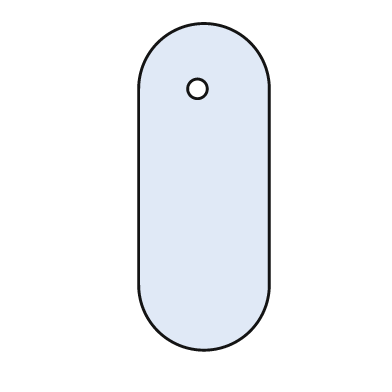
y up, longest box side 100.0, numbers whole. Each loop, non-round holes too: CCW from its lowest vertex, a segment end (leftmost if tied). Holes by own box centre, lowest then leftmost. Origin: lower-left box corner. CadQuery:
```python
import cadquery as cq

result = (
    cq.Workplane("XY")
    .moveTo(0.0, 20.0)
    .threePointArc((20.0, 0.0), (40.0, 20.0))
    .lineTo(40.0, 80.0)
    .threePointArc((20.0, 100.0), (0.0, 80.0))
    .close()
    .moveTo(18.0, 80.0)
    .circle(3.0)
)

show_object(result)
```